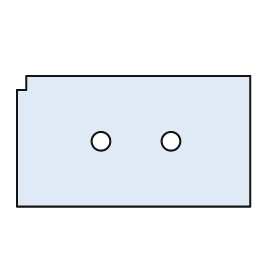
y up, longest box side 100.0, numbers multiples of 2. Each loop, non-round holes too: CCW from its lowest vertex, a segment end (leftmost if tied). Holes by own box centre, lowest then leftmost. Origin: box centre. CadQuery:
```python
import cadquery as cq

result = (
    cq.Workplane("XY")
    .moveTo(-50.0, -28.0)
    .lineTo(50.0, -28.0)
    .lineTo(50.0, 28.0)
    .lineTo(-46.0, 28.0)
    .lineTo(-46.0, 22.0)
    .lineTo(-50.0, 22.0)
    .close()
    .moveTo(-14.0, 0.0)
    .circle(4.0)
    .moveTo(16.0, 0.0)
    .circle(4.0)
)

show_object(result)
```